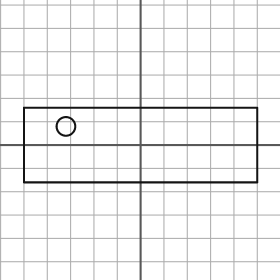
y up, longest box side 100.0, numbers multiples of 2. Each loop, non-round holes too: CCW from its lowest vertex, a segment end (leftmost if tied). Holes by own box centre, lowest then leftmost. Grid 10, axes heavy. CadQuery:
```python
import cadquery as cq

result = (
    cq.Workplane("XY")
    .moveTo(-50.0, -16.0)
    .lineTo(50.0, -16.0)
    .lineTo(50.0, 16.0)
    .lineTo(-50.0, 16.0)
    .close()
    .moveTo(-32.0, 8.0)
    .circle(4.0)
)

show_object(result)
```